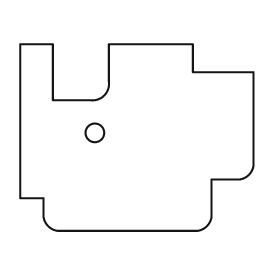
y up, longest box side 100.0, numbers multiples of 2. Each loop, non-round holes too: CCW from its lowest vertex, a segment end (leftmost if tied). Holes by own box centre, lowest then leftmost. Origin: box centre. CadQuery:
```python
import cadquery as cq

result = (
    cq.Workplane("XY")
    .moveTo(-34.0, -40.0)
    .lineTo(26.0, -40.0)
    .threePointArc((30.0, -38.0), (32.0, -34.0))
    .lineTo(32.0, -18.0)
    .lineTo(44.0, -18.0)
    .threePointArc((48.0, -16.0), (50.0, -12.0))
    .lineTo(50.0, 28.0)
    .lineTo(24.0, 28.0)
    .lineTo(24.0, 40.0)
    .lineTo(-12.0, 40.0)
    .lineTo(-12.0, 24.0)
    .threePointArc((-14.0, 18.0), (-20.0, 16.0))
    .lineTo(-36.0, 16.0)
    .lineTo(-36.0, 40.0)
    .lineTo(-50.0, 40.0)
    .lineTo(-50.0, -26.0)
    .lineTo(-40.0, -26.0)
    .lineTo(-40.0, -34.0)
    .threePointArc((-38.0, -38.0), (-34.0, -40.0))
    .close()
    .moveTo(-18.0, 2.0)
    .circle(4.0)
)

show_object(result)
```